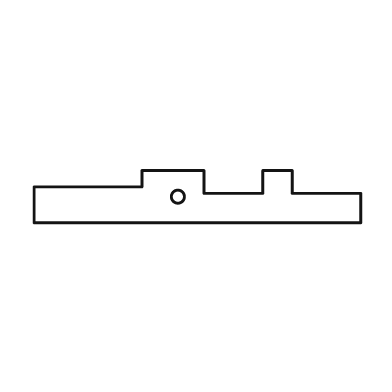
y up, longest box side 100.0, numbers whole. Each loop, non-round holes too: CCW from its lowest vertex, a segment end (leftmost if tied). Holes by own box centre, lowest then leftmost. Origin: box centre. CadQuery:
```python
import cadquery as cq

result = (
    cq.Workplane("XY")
    .moveTo(-50.0, -8.0)
    .lineTo(50.0, -8.0)
    .lineTo(50.0, 1.0)
    .lineTo(29.0, 1.0)
    .lineTo(29.0, 8.0)
    .lineTo(20.0, 8.0)
    .lineTo(20.0, 1.0)
    .lineTo(2.0, 1.0)
    .lineTo(2.0, 8.0)
    .lineTo(-17.0, 8.0)
    .lineTo(-17.0, 3.0)
    .lineTo(-50.0, 3.0)
    .close()
    .moveTo(-6.0, 0.0)
    .circle(2.0)
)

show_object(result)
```